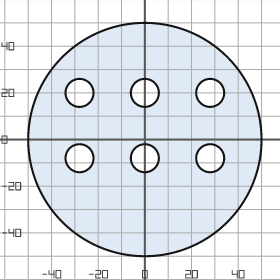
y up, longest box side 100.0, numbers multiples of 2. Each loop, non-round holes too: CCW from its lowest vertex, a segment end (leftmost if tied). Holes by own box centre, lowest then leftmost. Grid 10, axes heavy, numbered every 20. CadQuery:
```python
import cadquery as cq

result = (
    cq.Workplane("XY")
    .moveTo(0.0, 0.0)
    .circle(50.0)
    .moveTo(-28.0, -8.0)
    .circle(6.0)
    .moveTo(0.0, -8.0)
    .circle(6.0)
    .moveTo(28.0, -8.0)
    .circle(6.0)
    .moveTo(-28.0, 20.0)
    .circle(6.0)
    .moveTo(0.0, 20.0)
    .circle(6.0)
    .moveTo(28.0, 20.0)
    .circle(6.0)
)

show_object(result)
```